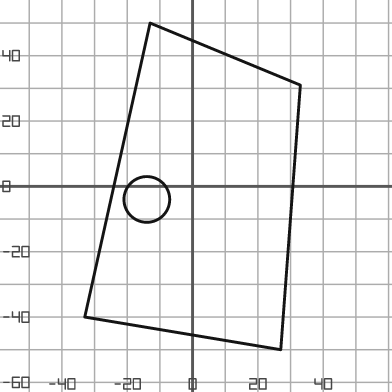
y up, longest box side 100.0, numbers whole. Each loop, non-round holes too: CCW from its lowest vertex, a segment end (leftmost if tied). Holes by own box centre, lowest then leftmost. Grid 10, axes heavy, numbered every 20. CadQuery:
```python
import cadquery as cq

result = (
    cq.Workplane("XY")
    .moveTo(27.0, -50.0)
    .lineTo(33.0, 31.0)
    .lineTo(-13.0, 50.0)
    .lineTo(-33.0, -40.0)
    .close()
    .moveTo(-14.0, -4.0)
    .circle(7.0)
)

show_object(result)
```